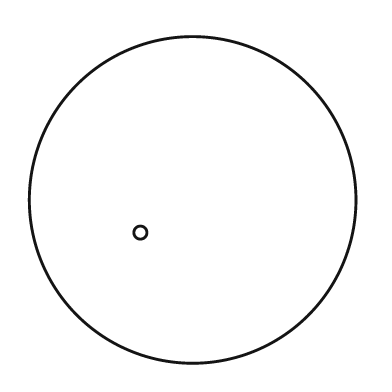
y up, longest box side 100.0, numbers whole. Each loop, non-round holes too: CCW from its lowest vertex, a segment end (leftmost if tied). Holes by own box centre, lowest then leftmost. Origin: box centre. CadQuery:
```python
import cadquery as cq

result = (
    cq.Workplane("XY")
    .moveTo(0.0, 0.0)
    .circle(50.0)
    .moveTo(-16.0, -10.0)
    .circle(2.0)
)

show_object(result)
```